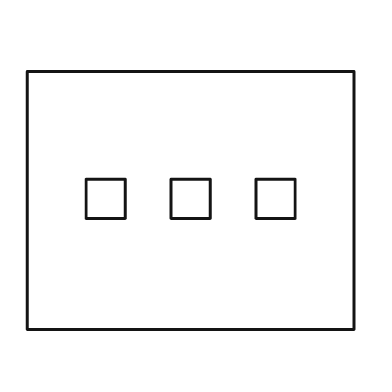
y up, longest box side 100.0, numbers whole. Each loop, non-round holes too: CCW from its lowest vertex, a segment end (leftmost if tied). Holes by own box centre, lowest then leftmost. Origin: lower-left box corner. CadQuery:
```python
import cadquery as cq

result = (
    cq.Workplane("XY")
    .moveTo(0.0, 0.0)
    .lineTo(100.0, 0.0)
    .lineTo(100.0, 79.0)
    .lineTo(0.0, 79.0)
    .close()
    .moveTo(18.0, 34.0)
    .lineTo(30.0, 34.0)
    .lineTo(30.0, 46.0)
    .lineTo(18.0, 46.0)
    .close()
    .moveTo(44.0, 34.0)
    .lineTo(56.0, 34.0)
    .lineTo(56.0, 46.0)
    .lineTo(44.0, 46.0)
    .close()
    .moveTo(70.0, 34.0)
    .lineTo(82.0, 34.0)
    .lineTo(82.0, 46.0)
    .lineTo(70.0, 46.0)
    .close()
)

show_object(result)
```